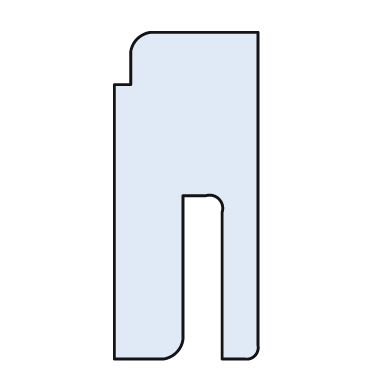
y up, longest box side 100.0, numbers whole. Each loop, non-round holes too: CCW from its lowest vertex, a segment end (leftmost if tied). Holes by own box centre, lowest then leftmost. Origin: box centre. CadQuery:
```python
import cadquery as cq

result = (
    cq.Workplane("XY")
    .moveTo(-22.0, -50.0)
    .lineTo(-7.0, -50.0)
    .threePointArc((-3.0, -48.0), (-1.0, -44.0))
    .lineTo(-1.0, 0.0)
    .lineTo(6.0, 0.0)
    .threePointArc((10.0, -1.0), (11.0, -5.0))
    .lineTo(11.0, -50.0)
    .lineTo(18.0, -50.0)
    .threePointArc((21.0, -49.0), (22.0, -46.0))
    .lineTo(22.0, 50.0)
    .lineTo(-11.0, 50.0)
    .threePointArc((-15.0, 48.0), (-17.0, 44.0))
    .lineTo(-17.0, 34.0)
    .lineTo(-22.0, 34.0)
    .close()
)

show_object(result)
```